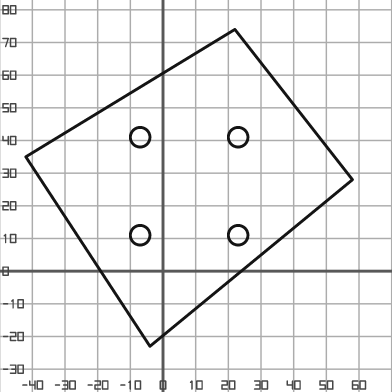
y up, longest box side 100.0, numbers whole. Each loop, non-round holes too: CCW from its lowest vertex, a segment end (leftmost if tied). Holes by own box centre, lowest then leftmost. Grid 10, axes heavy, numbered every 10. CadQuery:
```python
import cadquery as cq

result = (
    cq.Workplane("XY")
    .moveTo(-4.0, -23.0)
    .lineTo(58.0, 28.0)
    .lineTo(22.0, 74.0)
    .lineTo(-42.0, 35.0)
    .close()
    .moveTo(-7.0, 11.0)
    .circle(3.0)
    .moveTo(23.0, 11.0)
    .circle(3.0)
    .moveTo(-7.0, 41.0)
    .circle(3.0)
    .moveTo(23.0, 41.0)
    .circle(3.0)
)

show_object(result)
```